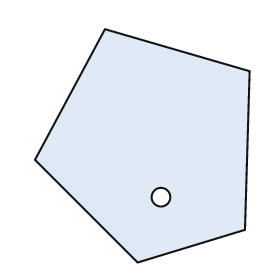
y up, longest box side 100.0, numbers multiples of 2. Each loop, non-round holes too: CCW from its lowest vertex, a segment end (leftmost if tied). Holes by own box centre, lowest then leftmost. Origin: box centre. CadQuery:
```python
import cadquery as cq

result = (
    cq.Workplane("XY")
    .moveTo(-2.0, -50.0)
    .lineTo(44.0, -36.0)
    .lineTo(46.0, 32.0)
    .lineTo(-16.0, 50.0)
    .lineTo(-46.0, -6.0)
    .close()
    .moveTo(8.0, -22.0)
    .circle(4.0)
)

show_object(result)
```